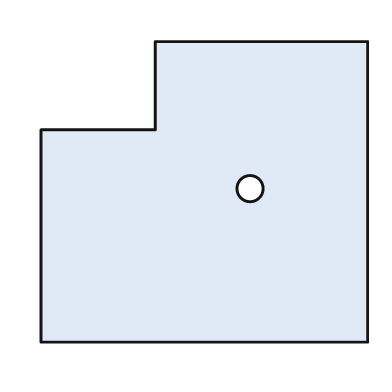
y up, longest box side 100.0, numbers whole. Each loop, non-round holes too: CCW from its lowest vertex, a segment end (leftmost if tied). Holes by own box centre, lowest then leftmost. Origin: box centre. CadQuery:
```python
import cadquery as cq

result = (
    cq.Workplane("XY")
    .moveTo(-50.0, -46.0)
    .lineTo(50.0, -46.0)
    .lineTo(50.0, 46.0)
    .lineTo(-15.0, 46.0)
    .lineTo(-15.0, 19.0)
    .lineTo(-50.0, 19.0)
    .close()
    .moveTo(14.0, 1.0)
    .circle(4.0)
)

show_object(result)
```